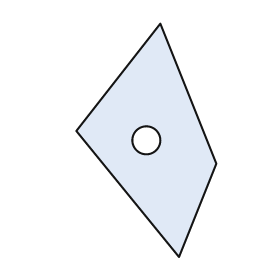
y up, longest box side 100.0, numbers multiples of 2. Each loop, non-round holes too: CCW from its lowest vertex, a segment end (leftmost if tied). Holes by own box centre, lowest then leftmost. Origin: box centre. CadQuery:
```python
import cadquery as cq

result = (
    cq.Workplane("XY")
    .moveTo(14.0, -50.0)
    .lineTo(30.0, -10.0)
    .lineTo(6.0, 50.0)
    .lineTo(-30.0, 4.0)
    .close()
    .moveTo(0.0, 0.0)
    .circle(6.0)
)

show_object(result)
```